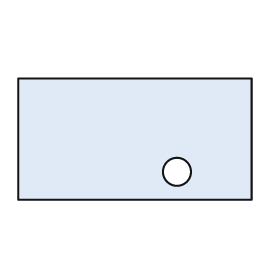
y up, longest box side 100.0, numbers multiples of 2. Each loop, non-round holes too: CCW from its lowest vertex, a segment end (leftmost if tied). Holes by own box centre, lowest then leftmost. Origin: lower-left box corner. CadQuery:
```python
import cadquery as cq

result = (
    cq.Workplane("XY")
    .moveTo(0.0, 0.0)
    .lineTo(100.0, 0.0)
    .lineTo(100.0, 52.0)
    .lineTo(0.0, 52.0)
    .close()
    .moveTo(68.0, 12.0)
    .circle(6.0)
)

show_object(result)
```